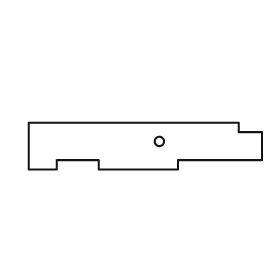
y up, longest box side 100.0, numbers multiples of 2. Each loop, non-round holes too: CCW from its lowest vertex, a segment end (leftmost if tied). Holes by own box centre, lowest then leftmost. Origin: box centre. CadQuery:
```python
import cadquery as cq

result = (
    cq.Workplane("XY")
    .moveTo(-50.0, -10.0)
    .lineTo(-38.0, -10.0)
    .lineTo(-38.0, -6.0)
    .lineTo(-20.0, -6.0)
    .lineTo(-20.0, -10.0)
    .lineTo(14.0, -10.0)
    .lineTo(14.0, -6.0)
    .lineTo(50.0, -6.0)
    .lineTo(50.0, 6.0)
    .lineTo(40.0, 6.0)
    .lineTo(40.0, 10.0)
    .lineTo(-50.0, 10.0)
    .close()
    .moveTo(6.0, 2.0)
    .circle(2.0)
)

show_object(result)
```